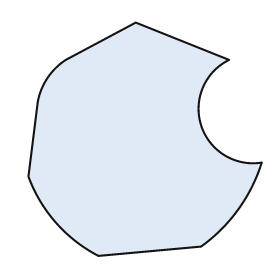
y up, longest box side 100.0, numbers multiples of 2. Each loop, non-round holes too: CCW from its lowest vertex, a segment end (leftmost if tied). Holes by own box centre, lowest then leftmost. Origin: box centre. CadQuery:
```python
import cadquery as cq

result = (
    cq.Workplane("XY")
    .moveTo(-20.0, -50.0)
    .lineTo(24.0, -46.0)
    .threePointArc((40.0, -30.0), (50.0, -10.0))
    .threePointArc((24.0, 6.0), (36.0, 34.0))
    .lineTo(-4.0, 50.0)
    .lineTo(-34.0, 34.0)
    .threePointArc((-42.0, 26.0), (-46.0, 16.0))
    .lineTo(-50.0, -16.0)
    .threePointArc((-38.0, -36.0), (-20.0, -50.0))
    .close()
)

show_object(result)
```